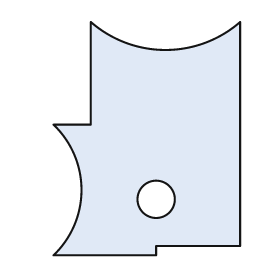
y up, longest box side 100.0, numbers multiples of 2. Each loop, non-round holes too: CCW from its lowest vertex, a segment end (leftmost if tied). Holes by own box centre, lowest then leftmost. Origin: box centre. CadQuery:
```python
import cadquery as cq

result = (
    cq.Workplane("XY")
    .moveTo(-40.0, -50.0)
    .lineTo(4.0, -50.0)
    .lineTo(4.0, -46.0)
    .lineTo(40.0, -46.0)
    .lineTo(40.0, 50.0)
    .threePointArc((8.0, 38.0), (-24.0, 50.0))
    .lineTo(-24.0, 6.0)
    .lineTo(-40.0, 6.0)
    .threePointArc((-28.0, -22.0), (-40.0, -50.0))
    .close()
    .moveTo(4.0, -26.0)
    .circle(8.0)
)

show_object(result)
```